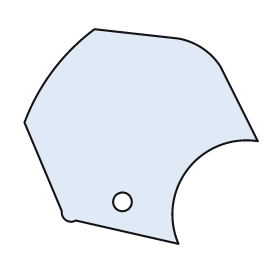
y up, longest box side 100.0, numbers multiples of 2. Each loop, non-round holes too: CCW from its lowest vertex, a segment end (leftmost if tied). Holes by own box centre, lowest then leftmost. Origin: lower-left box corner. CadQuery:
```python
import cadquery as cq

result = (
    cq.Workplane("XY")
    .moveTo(66.0, 0.0)
    .threePointArc((70.0, 32.0), (100.0, 44.0))
    .lineTo(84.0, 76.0)
    .threePointArc((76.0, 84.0), (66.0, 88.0))
    .lineTo(30.0, 92.0)
    .threePointArc((12.0, 74.0), (0.0, 52.0))
    .lineTo(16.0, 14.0)
    .threePointArc((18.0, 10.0), (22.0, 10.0))
    .close()
    .moveTo(42.0, 18.0)
    .circle(4.0)
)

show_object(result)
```